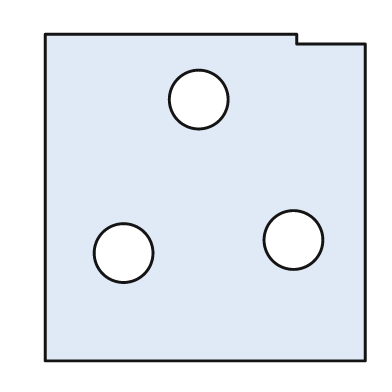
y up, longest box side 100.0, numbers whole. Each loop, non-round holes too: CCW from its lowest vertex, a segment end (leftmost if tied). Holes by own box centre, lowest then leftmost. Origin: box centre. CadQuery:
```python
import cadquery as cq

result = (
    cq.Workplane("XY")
    .moveTo(-49.0, -50.0)
    .lineTo(49.0, -50.0)
    .lineTo(49.0, 47.0)
    .lineTo(28.0, 47.0)
    .lineTo(28.0, 50.0)
    .lineTo(-49.0, 50.0)
    .close()
    .moveTo(-25.0, -17.0)
    .circle(9.0)
    .moveTo(27.0, -13.0)
    .circle(9.0)
    .moveTo(-2.0, 30.0)
    .circle(9.0)
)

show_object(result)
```